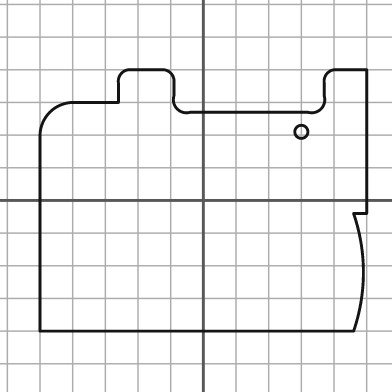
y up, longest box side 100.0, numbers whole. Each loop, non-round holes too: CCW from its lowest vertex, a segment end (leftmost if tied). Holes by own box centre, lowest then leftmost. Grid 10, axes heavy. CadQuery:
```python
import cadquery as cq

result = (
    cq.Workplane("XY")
    .moveTo(-50.0, -40.0)
    .lineTo(46.0, -40.0)
    .threePointArc((49.0, -22.0), (46.0, -4.0))
    .lineTo(50.0, -4.0)
    .lineTo(50.0, 40.0)
    .lineTo(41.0, 40.0)
    .threePointArc((38.0, 39.0), (37.0, 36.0))
    .lineTo(37.0, 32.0)
    .threePointArc((36.0, 28.0), (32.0, 27.0))
    .lineTo(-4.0, 27.0)
    .threePointArc((-8.0, 28.0), (-9.0, 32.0))
    .lineTo(-9.0, 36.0)
    .threePointArc((-10.0, 39.0), (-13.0, 40.0))
    .lineTo(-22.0, 40.0)
    .threePointArc((-25.0, 39.0), (-26.0, 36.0))
    .lineTo(-26.0, 30.0)
    .lineTo(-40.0, 30.0)
    .threePointArc((-47.0, 27.0), (-50.0, 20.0))
    .close()
    .moveTo(30.0, 21.0)
    .circle(2.0)
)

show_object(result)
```